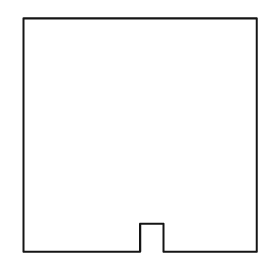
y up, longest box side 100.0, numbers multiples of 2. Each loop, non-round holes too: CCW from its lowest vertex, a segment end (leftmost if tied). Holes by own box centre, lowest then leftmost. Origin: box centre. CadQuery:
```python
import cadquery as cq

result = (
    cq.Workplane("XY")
    .moveTo(-50.0, -50.0)
    .lineTo(0.0, -50.0)
    .lineTo(0.0, -38.0)
    .lineTo(10.0, -38.0)
    .lineTo(10.0, -50.0)
    .lineTo(50.0, -50.0)
    .lineTo(50.0, 50.0)
    .lineTo(-50.0, 50.0)
    .close()
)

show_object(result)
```